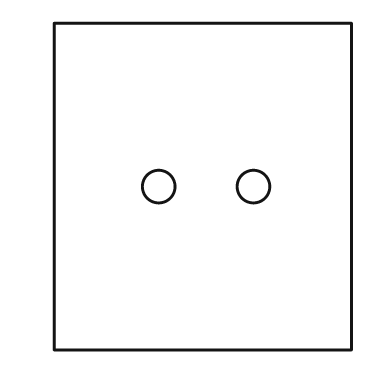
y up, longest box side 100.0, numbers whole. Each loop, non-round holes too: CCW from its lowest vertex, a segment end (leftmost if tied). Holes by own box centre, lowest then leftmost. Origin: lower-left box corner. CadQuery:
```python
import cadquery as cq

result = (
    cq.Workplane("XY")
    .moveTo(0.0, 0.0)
    .lineTo(91.0, 0.0)
    .lineTo(91.0, 100.0)
    .lineTo(0.0, 100.0)
    .close()
    .moveTo(32.0, 50.0)
    .circle(5.0)
    .moveTo(61.0, 50.0)
    .circle(5.0)
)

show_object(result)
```